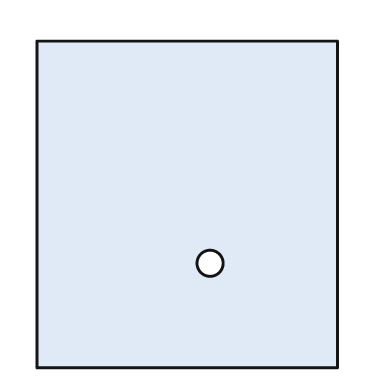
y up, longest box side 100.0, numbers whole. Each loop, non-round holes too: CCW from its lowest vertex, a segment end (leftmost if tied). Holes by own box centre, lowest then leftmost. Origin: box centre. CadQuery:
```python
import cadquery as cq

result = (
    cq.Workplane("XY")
    .moveTo(-46.0, -50.0)
    .lineTo(46.0, -50.0)
    .lineTo(46.0, 50.0)
    .lineTo(-46.0, 50.0)
    .close()
    .moveTo(7.0, -18.0)
    .circle(4.0)
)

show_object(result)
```